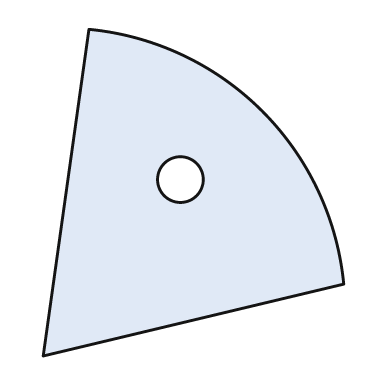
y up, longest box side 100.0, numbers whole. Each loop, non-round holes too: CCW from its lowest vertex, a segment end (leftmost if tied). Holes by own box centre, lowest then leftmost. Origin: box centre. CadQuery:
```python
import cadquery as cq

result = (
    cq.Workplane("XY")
    .moveTo(-46.0, -50.0)
    .lineTo(46.0, -28.0)
    .threePointArc((21.0, 25.0), (-32.0, 50.0))
    .close()
    .moveTo(-4.0, 4.0)
    .circle(7.0)
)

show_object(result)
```